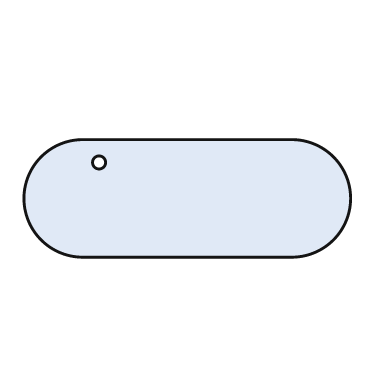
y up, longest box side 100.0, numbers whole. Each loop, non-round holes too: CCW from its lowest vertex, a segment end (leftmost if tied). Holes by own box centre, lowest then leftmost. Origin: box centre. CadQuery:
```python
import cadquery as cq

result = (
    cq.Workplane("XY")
    .moveTo(-32.0, -18.0)
    .lineTo(32.0, -18.0)
    .threePointArc((50.0, 0.0), (32.0, 18.0))
    .lineTo(-32.0, 18.0)
    .threePointArc((-50.0, 0.0), (-32.0, -18.0))
    .close()
    .moveTo(-27.0, 11.0)
    .circle(2.0)
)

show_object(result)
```